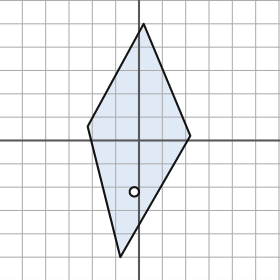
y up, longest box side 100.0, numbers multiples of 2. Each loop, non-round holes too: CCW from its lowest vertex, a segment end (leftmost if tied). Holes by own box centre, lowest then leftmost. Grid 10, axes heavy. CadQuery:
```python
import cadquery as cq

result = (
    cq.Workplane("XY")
    .moveTo(-8.0, -50.0)
    .lineTo(22.0, 2.0)
    .lineTo(2.0, 50.0)
    .lineTo(-22.0, 6.0)
    .close()
    .moveTo(-2.0, -22.0)
    .circle(2.0)
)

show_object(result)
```